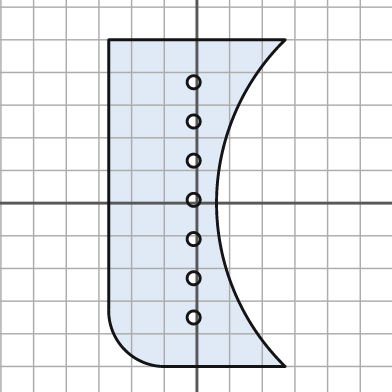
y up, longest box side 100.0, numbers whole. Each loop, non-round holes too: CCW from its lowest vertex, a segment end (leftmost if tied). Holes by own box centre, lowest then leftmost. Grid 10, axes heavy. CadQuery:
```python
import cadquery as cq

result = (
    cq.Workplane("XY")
    .moveTo(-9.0, -50.0)
    .lineTo(27.0, -50.0)
    .threePointArc((6.0, 0.0), (27.0, 50.0))
    .lineTo(-27.0, 50.0)
    .lineTo(-27.0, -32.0)
    .threePointArc((-22.0, -45.0), (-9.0, -50.0))
    .close()
    .moveTo(-1.0, -35.0)
    .circle(2.0)
    .moveTo(-1.0, -23.0)
    .circle(2.0)
    .moveTo(-1.0, -11.0)
    .circle(2.0)
    .moveTo(-1.0, 1.0)
    .circle(2.0)
    .moveTo(-1.0, 13.0)
    .circle(2.0)
    .moveTo(-1.0, 25.0)
    .circle(2.0)
    .moveTo(-1.0, 37.0)
    .circle(2.0)
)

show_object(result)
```